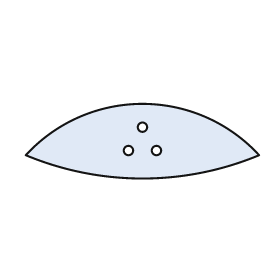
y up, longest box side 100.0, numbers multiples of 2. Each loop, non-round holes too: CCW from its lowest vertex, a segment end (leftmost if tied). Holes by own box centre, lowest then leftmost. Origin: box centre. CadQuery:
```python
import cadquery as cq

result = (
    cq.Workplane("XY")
    .moveTo(-50.0, -6.0)
    .threePointArc((0.0, -16.0), (50.0, -6.0))
    .threePointArc((0.0, 16.0), (-50.0, -6.0))
    .close()
    .moveTo(-6.0, -4.0)
    .circle(2.0)
    .moveTo(6.0, -4.0)
    .circle(2.0)
    .moveTo(0.0, 6.0)
    .circle(2.0)
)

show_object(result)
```